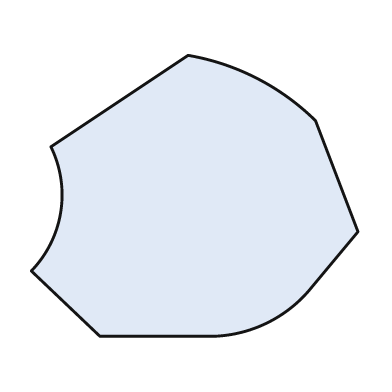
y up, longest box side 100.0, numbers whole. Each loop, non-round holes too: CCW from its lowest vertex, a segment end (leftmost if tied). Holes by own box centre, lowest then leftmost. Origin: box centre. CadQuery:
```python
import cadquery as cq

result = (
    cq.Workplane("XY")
    .moveTo(-29.0, -43.0)
    .lineTo(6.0, -43.0)
    .threePointArc((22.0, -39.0), (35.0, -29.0))
    .lineTo(50.0, -11.0)
    .lineTo(37.0, 23.0)
    .threePointArc((19.0, 36.0), (-2.0, 43.0))
    .lineTo(-44.0, 15.0)
    .threePointArc((-41.0, -5.0), (-50.0, -23.0))
    .close()
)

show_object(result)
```